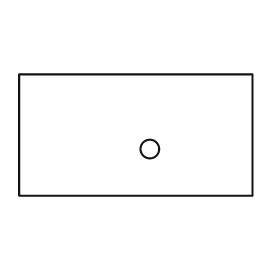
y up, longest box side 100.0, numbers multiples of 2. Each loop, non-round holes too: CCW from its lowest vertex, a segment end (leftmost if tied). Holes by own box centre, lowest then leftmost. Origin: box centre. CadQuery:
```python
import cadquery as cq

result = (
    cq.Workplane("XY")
    .moveTo(-50.0, -26.0)
    .lineTo(50.0, -26.0)
    .lineTo(50.0, 26.0)
    .lineTo(-50.0, 26.0)
    .close()
    .moveTo(6.0, -6.0)
    .circle(4.0)
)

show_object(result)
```